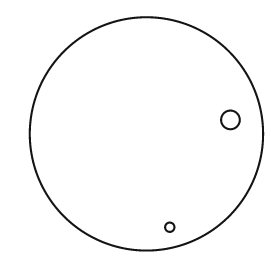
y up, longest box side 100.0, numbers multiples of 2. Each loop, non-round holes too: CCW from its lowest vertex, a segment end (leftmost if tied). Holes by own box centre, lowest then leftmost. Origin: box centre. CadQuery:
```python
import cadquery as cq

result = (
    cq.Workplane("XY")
    .moveTo(0.0, 0.0)
    .circle(50.0)
    .moveTo(10.0, -40.0)
    .circle(2.0)
    .moveTo(36.0, 6.0)
    .circle(4.0)
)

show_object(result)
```